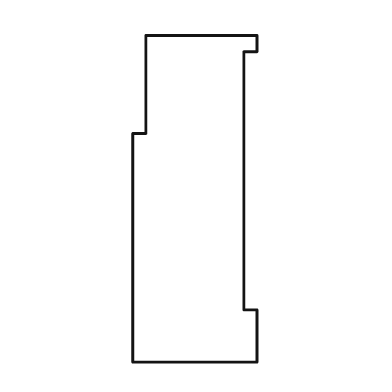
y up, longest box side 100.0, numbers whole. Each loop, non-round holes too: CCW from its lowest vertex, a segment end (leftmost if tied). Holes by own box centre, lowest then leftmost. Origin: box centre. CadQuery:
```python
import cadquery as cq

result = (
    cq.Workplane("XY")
    .moveTo(-19.0, -50.0)
    .lineTo(19.0, -50.0)
    .lineTo(19.0, -34.0)
    .lineTo(15.0, -34.0)
    .lineTo(15.0, 45.0)
    .lineTo(19.0, 45.0)
    .lineTo(19.0, 50.0)
    .lineTo(-15.0, 50.0)
    .lineTo(-15.0, 20.0)
    .lineTo(-19.0, 20.0)
    .close()
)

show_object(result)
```